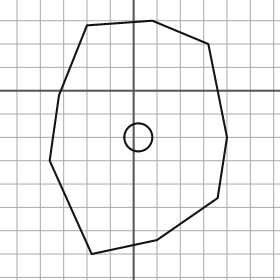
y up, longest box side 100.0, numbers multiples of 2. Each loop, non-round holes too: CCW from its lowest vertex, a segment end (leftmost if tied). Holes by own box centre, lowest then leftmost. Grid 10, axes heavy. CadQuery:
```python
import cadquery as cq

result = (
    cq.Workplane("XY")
    .moveTo(-18.0, -70.0)
    .lineTo(10.0, -64.0)
    .lineTo(36.0, -46.0)
    .lineTo(40.0, -20.0)
    .lineTo(32.0, 20.0)
    .lineTo(8.0, 30.0)
    .lineTo(-20.0, 28.0)
    .lineTo(-32.0, -2.0)
    .lineTo(-36.0, -30.0)
    .close()
    .moveTo(2.0, -20.0)
    .circle(6.0)
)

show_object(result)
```